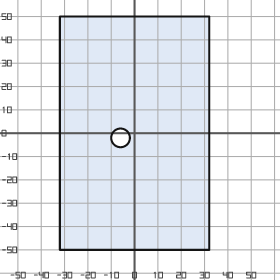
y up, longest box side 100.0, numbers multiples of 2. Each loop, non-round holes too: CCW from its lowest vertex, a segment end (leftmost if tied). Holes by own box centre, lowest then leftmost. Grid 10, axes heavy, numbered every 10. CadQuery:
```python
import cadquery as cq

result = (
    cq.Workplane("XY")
    .moveTo(-32.0, -50.0)
    .lineTo(32.0, -50.0)
    .lineTo(32.0, 50.0)
    .lineTo(-32.0, 50.0)
    .close()
    .moveTo(-6.0, -2.0)
    .circle(4.0)
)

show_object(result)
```